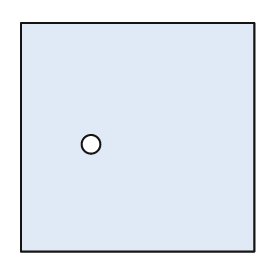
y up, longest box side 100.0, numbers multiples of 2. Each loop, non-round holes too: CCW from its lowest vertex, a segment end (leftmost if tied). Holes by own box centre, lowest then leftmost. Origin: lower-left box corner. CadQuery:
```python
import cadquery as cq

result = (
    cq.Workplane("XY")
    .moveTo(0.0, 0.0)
    .lineTo(100.0, 0.0)
    .lineTo(100.0, 98.0)
    .lineTo(0.0, 98.0)
    .close()
    .moveTo(30.0, 46.0)
    .circle(4.0)
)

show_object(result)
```